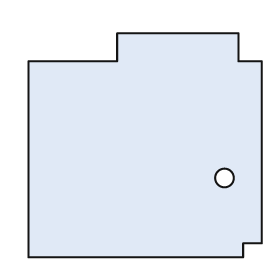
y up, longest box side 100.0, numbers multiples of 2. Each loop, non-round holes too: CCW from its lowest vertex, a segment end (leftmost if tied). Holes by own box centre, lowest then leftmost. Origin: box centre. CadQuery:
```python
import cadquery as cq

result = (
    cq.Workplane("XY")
    .moveTo(-50.0, -48.0)
    .lineTo(42.0, -48.0)
    .lineTo(42.0, -42.0)
    .lineTo(50.0, -42.0)
    .lineTo(50.0, 36.0)
    .lineTo(40.0, 36.0)
    .lineTo(40.0, 48.0)
    .lineTo(-12.0, 48.0)
    .lineTo(-12.0, 36.0)
    .lineTo(-50.0, 36.0)
    .close()
    .moveTo(34.0, -14.0)
    .circle(4.0)
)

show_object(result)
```